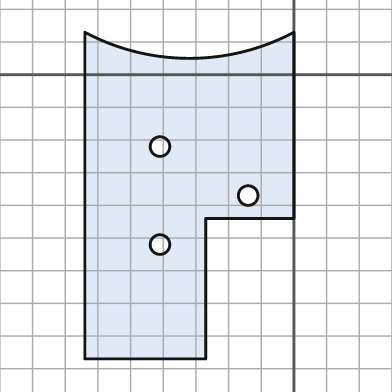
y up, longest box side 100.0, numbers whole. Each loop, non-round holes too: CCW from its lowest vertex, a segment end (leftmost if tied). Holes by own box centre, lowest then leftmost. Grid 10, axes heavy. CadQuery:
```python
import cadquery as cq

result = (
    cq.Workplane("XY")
    .moveTo(-64.0, -87.0)
    .lineTo(-27.0, -87.0)
    .lineTo(-27.0, -44.0)
    .lineTo(0.0, -44.0)
    .lineTo(0.0, 13.0)
    .threePointArc((-32.0, 5.0), (-64.0, 13.0))
    .close()
    .moveTo(-41.0, -52.0)
    .circle(3.0)
    .moveTo(-14.0, -37.0)
    .circle(3.0)
    .moveTo(-41.0, -22.0)
    .circle(3.0)
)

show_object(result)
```